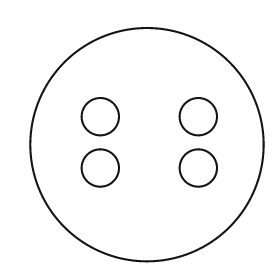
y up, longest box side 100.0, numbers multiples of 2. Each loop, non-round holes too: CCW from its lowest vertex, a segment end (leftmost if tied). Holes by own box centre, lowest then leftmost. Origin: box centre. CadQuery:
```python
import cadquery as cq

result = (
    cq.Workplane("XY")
    .moveTo(0.0, 0.0)
    .circle(50.0)
    .moveTo(-20.0, -10.0)
    .circle(8.0)
    .moveTo(22.0, -10.0)
    .circle(8.0)
    .moveTo(-20.0, 12.0)
    .circle(8.0)
    .moveTo(22.0, 12.0)
    .circle(8.0)
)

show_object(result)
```